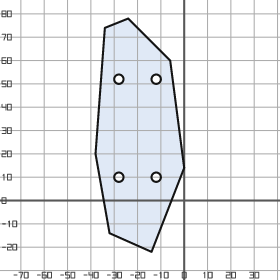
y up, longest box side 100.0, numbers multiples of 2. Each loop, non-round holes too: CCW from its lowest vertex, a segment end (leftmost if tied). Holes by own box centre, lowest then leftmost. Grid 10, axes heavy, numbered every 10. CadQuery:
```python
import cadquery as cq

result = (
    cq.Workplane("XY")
    .moveTo(-14.0, -22.0)
    .lineTo(0.0, 14.0)
    .lineTo(-6.0, 60.0)
    .lineTo(-24.0, 78.0)
    .lineTo(-34.0, 74.0)
    .lineTo(-38.0, 20.0)
    .lineTo(-32.0, -14.0)
    .close()
    .moveTo(-28.0, 10.0)
    .circle(2.0)
    .moveTo(-12.0, 10.0)
    .circle(2.0)
    .moveTo(-28.0, 52.0)
    .circle(2.0)
    .moveTo(-12.0, 52.0)
    .circle(2.0)
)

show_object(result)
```